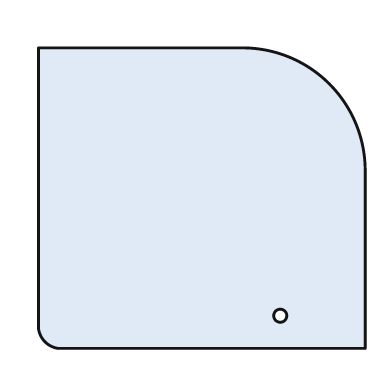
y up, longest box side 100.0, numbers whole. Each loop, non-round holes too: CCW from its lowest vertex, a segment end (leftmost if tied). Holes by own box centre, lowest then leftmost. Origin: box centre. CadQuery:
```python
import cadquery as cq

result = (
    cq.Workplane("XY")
    .moveTo(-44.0, -46.0)
    .lineTo(50.0, -46.0)
    .lineTo(50.0, 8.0)
    .threePointArc((39.0, 35.0), (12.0, 46.0))
    .lineTo(-50.0, 46.0)
    .lineTo(-50.0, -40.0)
    .threePointArc((-48.0, -44.0), (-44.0, -46.0))
    .close()
    .moveTo(24.0, -36.0)
    .circle(2.0)
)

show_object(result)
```